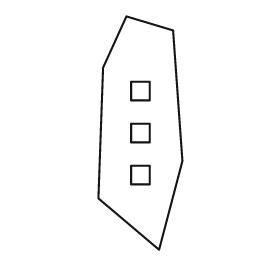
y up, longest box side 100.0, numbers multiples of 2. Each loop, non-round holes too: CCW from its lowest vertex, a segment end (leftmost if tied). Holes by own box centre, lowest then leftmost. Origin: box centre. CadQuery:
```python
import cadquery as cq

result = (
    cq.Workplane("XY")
    .moveTo(8.0, -50.0)
    .lineTo(18.0, -12.0)
    .lineTo(14.0, 44.0)
    .lineTo(-6.0, 50.0)
    .lineTo(-16.0, 28.0)
    .lineTo(-18.0, -28.0)
    .close()
    .moveTo(-4.0, -22.0)
    .lineTo(4.0, -22.0)
    .lineTo(4.0, -14.0)
    .lineTo(-4.0, -14.0)
    .close()
    .moveTo(-4.0, -4.0)
    .lineTo(4.0, -4.0)
    .lineTo(4.0, 4.0)
    .lineTo(-4.0, 4.0)
    .close()
    .moveTo(-4.0, 14.0)
    .lineTo(4.0, 14.0)
    .lineTo(4.0, 22.0)
    .lineTo(-4.0, 22.0)
    .close()
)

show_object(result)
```